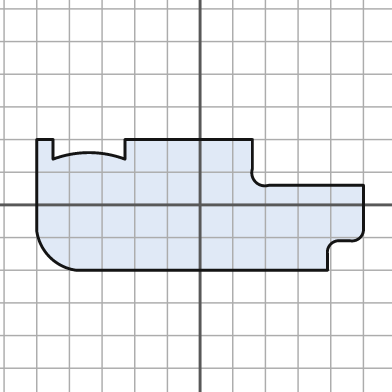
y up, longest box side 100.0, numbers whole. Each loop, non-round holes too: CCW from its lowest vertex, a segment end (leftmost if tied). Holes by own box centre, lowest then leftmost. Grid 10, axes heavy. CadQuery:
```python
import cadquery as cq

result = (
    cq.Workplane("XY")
    .moveTo(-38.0, -20.0)
    .lineTo(39.0, -20.0)
    .lineTo(39.0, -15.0)
    .threePointArc((40.0, -12.0), (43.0, -11.0))
    .lineTo(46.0, -11.0)
    .threePointArc((49.0, -10.0), (50.0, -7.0))
    .lineTo(50.0, 6.0)
    .lineTo(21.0, 6.0)
    .threePointArc((17.0, 7.0), (16.0, 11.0))
    .lineTo(16.0, 20.0)
    .lineTo(-23.0, 20.0)
    .lineTo(-23.0, 14.0)
    .threePointArc((-34.0, 16.0), (-45.0, 14.0))
    .lineTo(-45.0, 20.0)
    .lineTo(-50.0, 20.0)
    .lineTo(-50.0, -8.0)
    .threePointArc((-46.0, -16.0), (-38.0, -20.0))
    .close()
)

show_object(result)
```